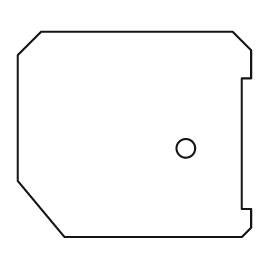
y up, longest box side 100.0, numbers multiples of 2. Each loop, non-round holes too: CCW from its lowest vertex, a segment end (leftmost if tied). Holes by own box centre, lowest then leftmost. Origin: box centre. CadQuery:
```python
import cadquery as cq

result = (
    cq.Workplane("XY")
    .moveTo(-30.0, -44.0)
    .lineTo(46.0, -44.0)
    .lineTo(50.0, -40.0)
    .lineTo(50.0, -32.0)
    .lineTo(46.0, -32.0)
    .lineTo(46.0, 24.0)
    .lineTo(50.0, 24.0)
    .lineTo(50.0, 36.0)
    .lineTo(42.0, 44.0)
    .lineTo(-40.0, 44.0)
    .lineTo(-50.0, 34.0)
    .lineTo(-50.0, -20.0)
    .close()
    .moveTo(22.0, -6.0)
    .circle(4.0)
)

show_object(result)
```